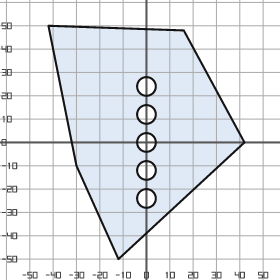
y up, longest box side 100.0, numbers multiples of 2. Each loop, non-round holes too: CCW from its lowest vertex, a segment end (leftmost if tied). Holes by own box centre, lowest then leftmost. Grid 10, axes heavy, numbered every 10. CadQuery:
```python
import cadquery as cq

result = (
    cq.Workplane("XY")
    .moveTo(-12.0, -50.0)
    .lineTo(42.0, 0.0)
    .lineTo(16.0, 48.0)
    .lineTo(-42.0, 50.0)
    .lineTo(-30.0, -10.0)
    .close()
    .moveTo(0.0, -24.0)
    .circle(4.0)
    .moveTo(0.0, -12.0)
    .circle(4.0)
    .moveTo(0.0, 0.0)
    .circle(4.0)
    .moveTo(0.0, 12.0)
    .circle(4.0)
    .moveTo(0.0, 24.0)
    .circle(4.0)
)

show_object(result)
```